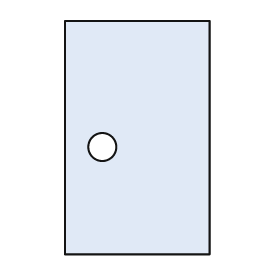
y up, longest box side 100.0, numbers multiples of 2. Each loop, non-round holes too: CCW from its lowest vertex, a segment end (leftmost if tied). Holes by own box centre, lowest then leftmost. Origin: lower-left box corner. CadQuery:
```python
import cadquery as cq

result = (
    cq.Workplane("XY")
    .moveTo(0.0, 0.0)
    .lineTo(62.0, 0.0)
    .lineTo(62.0, 100.0)
    .lineTo(0.0, 100.0)
    .close()
    .moveTo(16.0, 46.0)
    .circle(6.0)
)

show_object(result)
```